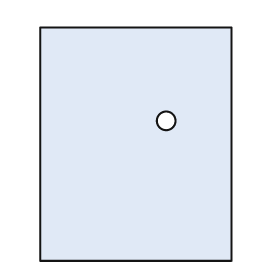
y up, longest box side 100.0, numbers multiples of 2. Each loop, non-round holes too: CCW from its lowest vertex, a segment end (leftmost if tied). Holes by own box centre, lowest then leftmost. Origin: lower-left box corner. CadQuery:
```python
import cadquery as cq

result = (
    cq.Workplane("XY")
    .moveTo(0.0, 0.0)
    .lineTo(82.0, 0.0)
    .lineTo(82.0, 100.0)
    .lineTo(0.0, 100.0)
    .close()
    .moveTo(54.0, 60.0)
    .circle(4.0)
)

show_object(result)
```